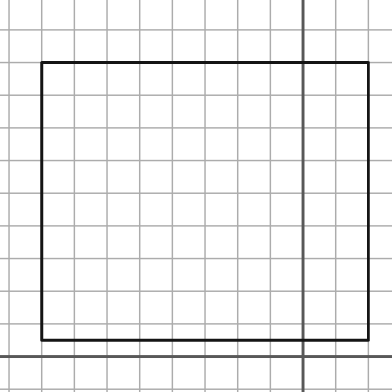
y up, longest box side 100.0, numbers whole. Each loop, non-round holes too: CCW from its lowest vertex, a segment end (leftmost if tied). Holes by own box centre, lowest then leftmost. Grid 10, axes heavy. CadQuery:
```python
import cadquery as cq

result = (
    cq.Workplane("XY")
    .moveTo(-80.0, 5.0)
    .lineTo(20.0, 5.0)
    .lineTo(20.0, 90.0)
    .lineTo(-80.0, 90.0)
    .close()
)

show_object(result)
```